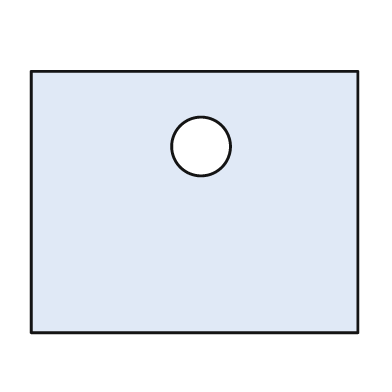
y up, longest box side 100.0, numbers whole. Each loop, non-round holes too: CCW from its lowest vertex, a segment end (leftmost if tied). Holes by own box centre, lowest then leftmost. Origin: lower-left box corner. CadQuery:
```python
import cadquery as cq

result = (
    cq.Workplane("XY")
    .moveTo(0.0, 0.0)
    .lineTo(100.0, 0.0)
    .lineTo(100.0, 80.0)
    .lineTo(0.0, 80.0)
    .close()
    .moveTo(52.0, 57.0)
    .circle(9.0)
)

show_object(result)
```